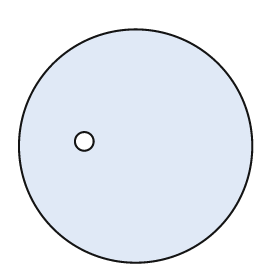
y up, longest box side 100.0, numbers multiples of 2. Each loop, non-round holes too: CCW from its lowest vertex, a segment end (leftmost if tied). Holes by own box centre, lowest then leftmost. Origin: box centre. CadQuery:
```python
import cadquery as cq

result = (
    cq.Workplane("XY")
    .moveTo(0.0, 0.0)
    .circle(50.0)
    .moveTo(-22.0, 2.0)
    .circle(4.0)
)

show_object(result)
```